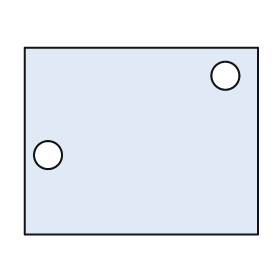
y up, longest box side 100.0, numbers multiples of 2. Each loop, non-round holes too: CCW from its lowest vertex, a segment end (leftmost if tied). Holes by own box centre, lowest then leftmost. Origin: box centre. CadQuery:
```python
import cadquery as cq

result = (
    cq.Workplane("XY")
    .moveTo(-50.0, -40.0)
    .lineTo(50.0, -40.0)
    .lineTo(50.0, 40.0)
    .lineTo(-50.0, 40.0)
    .close()
    .moveTo(-40.0, -6.0)
    .circle(6.0)
    .moveTo(36.0, 28.0)
    .circle(6.0)
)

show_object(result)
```